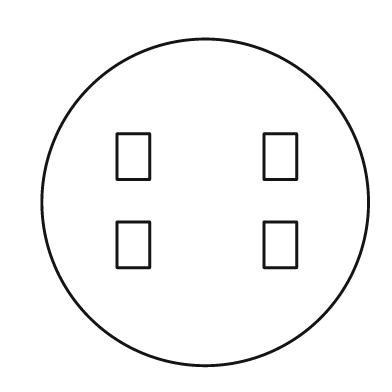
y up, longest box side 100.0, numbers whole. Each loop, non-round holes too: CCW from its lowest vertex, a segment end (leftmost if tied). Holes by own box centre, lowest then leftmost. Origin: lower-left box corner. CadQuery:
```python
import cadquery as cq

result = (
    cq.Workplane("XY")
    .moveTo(50.0, 50.0)
    .circle(50.0)
    .moveTo(23.0, 30.0)
    .lineTo(33.0, 30.0)
    .lineTo(33.0, 44.0)
    .lineTo(23.0, 44.0)
    .close()
    .moveTo(68.0, 30.0)
    .lineTo(78.0, 30.0)
    .lineTo(78.0, 44.0)
    .lineTo(68.0, 44.0)
    .close()
    .moveTo(23.0, 57.0)
    .lineTo(33.0, 57.0)
    .lineTo(33.0, 71.0)
    .lineTo(23.0, 71.0)
    .close()
    .moveTo(68.0, 57.0)
    .lineTo(78.0, 57.0)
    .lineTo(78.0, 71.0)
    .lineTo(68.0, 71.0)
    .close()
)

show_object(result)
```